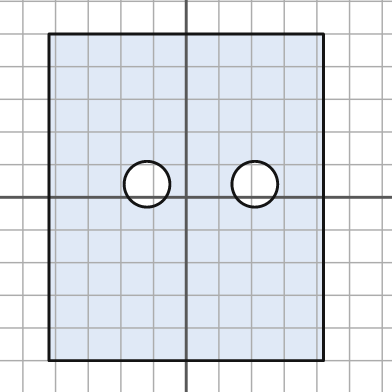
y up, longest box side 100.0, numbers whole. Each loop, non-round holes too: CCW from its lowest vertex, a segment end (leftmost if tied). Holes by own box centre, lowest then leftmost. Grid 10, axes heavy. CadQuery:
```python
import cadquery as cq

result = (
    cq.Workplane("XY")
    .moveTo(-42.0, -50.0)
    .lineTo(42.0, -50.0)
    .lineTo(42.0, 50.0)
    .lineTo(-42.0, 50.0)
    .close()
    .moveTo(-12.0, 4.0)
    .circle(7.0)
    .moveTo(21.0, 4.0)
    .circle(7.0)
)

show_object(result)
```